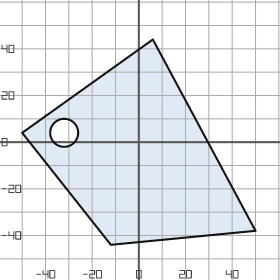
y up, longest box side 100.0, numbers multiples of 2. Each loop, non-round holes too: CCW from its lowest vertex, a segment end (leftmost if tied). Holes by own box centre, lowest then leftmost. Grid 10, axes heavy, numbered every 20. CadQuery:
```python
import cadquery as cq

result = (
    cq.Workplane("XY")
    .moveTo(-12.0, -44.0)
    .lineTo(50.0, -38.0)
    .lineTo(6.0, 44.0)
    .lineTo(-50.0, 4.0)
    .close()
    .moveTo(-32.0, 4.0)
    .circle(6.0)
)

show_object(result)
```